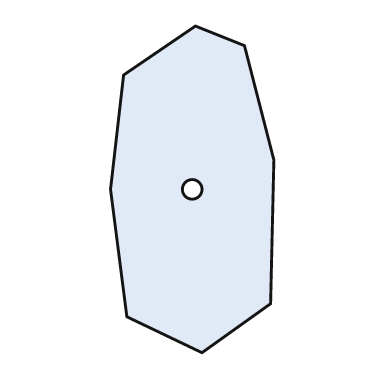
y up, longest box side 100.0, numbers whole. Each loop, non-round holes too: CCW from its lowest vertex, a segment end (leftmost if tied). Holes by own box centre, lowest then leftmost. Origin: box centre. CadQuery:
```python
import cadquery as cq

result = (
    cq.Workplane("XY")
    .moveTo(3.0, -50.0)
    .lineTo(24.0, -35.0)
    .lineTo(25.0, 9.0)
    .lineTo(16.0, 44.0)
    .lineTo(1.0, 50.0)
    .lineTo(-21.0, 35.0)
    .lineTo(-25.0, 0.0)
    .lineTo(-20.0, -39.0)
    .close()
    .moveTo(0.0, 0.0)
    .circle(3.0)
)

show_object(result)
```